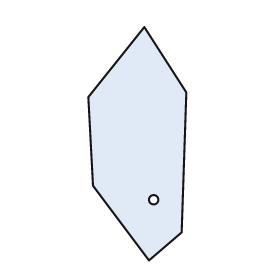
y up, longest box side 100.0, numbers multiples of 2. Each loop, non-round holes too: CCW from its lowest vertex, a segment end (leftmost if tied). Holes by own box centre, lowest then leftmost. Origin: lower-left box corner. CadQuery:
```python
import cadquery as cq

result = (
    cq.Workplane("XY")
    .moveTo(26.0, 0.0)
    .lineTo(40.0, 12.0)
    .lineTo(42.0, 72.0)
    .lineTo(24.0, 100.0)
    .lineTo(0.0, 70.0)
    .lineTo(2.0, 32.0)
    .close()
    .moveTo(28.0, 26.0)
    .circle(2.0)
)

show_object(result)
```